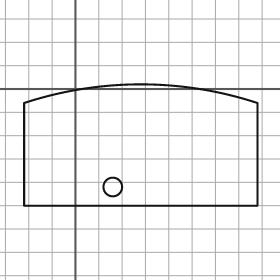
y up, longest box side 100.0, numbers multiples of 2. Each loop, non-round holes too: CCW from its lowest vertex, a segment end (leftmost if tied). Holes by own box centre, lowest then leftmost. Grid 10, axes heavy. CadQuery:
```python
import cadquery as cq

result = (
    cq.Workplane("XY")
    .moveTo(-22.0, -50.0)
    .lineTo(78.0, -50.0)
    .lineTo(78.0, -6.0)
    .threePointArc((28.0, 2.0), (-22.0, -6.0))
    .close()
    .moveTo(16.0, -42.0)
    .circle(4.0)
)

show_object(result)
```